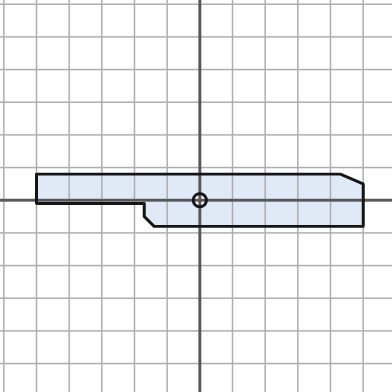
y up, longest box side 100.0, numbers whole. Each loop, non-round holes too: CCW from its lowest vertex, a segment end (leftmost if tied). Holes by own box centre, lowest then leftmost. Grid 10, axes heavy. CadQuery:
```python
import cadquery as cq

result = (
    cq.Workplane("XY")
    .moveTo(-14.0, -8.0)
    .lineTo(50.0, -8.0)
    .lineTo(50.0, 5.0)
    .lineTo(43.0, 8.0)
    .lineTo(-50.0, 8.0)
    .lineTo(-50.0, -1.0)
    .lineTo(-17.0, -1.0)
    .lineTo(-17.0, -5.0)
    .close()
    .moveTo(0.0, 0.0)
    .circle(2.0)
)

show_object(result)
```